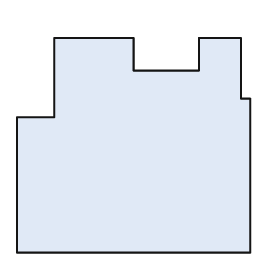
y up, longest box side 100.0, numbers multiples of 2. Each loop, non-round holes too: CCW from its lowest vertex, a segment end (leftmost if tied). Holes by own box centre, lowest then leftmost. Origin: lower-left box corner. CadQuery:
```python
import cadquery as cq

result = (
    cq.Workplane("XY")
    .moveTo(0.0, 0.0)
    .lineTo(100.0, 0.0)
    .lineTo(100.0, 66.0)
    .lineTo(96.0, 66.0)
    .lineTo(96.0, 92.0)
    .lineTo(78.0, 92.0)
    .lineTo(78.0, 78.0)
    .lineTo(50.0, 78.0)
    .lineTo(50.0, 92.0)
    .lineTo(16.0, 92.0)
    .lineTo(16.0, 58.0)
    .lineTo(0.0, 58.0)
    .close()
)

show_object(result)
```